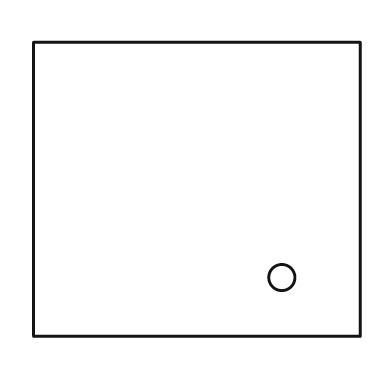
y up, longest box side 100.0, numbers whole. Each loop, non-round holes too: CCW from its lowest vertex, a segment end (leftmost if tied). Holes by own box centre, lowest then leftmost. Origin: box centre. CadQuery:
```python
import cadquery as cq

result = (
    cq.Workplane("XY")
    .moveTo(-50.0, -45.0)
    .lineTo(50.0, -45.0)
    .lineTo(50.0, 45.0)
    .lineTo(-50.0, 45.0)
    .close()
    .moveTo(26.0, -27.0)
    .circle(4.0)
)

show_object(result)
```